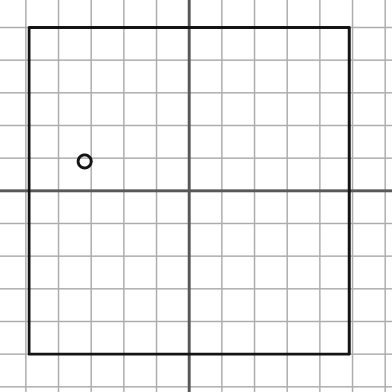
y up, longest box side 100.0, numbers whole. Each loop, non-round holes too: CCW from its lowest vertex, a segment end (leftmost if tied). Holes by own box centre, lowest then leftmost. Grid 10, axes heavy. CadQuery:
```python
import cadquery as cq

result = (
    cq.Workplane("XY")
    .moveTo(-49.0, -50.0)
    .lineTo(49.0, -50.0)
    .lineTo(49.0, 50.0)
    .lineTo(-49.0, 50.0)
    .close()
    .moveTo(-32.0, 9.0)
    .circle(2.0)
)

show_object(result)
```